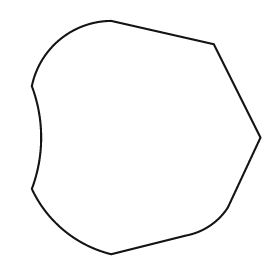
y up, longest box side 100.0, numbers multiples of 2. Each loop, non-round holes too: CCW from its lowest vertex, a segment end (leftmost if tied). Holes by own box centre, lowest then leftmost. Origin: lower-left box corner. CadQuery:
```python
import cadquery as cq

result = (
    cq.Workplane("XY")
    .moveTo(34.0, 0.0)
    .lineTo(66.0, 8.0)
    .threePointArc((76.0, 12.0), (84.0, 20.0))
    .lineTo(98.0, 50.0)
    .lineTo(78.0, 90.0)
    .lineTo(34.0, 100.0)
    .threePointArc((12.0, 92.0), (0.0, 72.0))
    .threePointArc((4.0, 50.0), (0.0, 28.0))
    .threePointArc((14.0, 10.0), (34.0, 0.0))
    .close()
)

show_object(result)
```